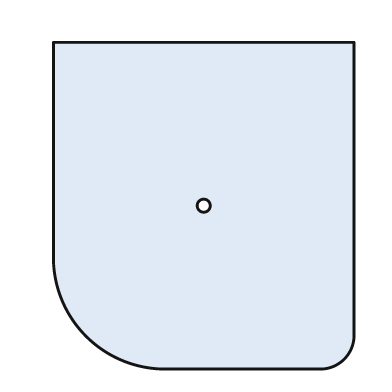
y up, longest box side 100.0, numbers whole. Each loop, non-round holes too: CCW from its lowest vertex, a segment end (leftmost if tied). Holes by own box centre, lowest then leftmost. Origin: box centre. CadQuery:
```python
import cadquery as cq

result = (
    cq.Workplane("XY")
    .moveTo(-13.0, -50.0)
    .lineTo(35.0, -50.0)
    .threePointArc((43.0, -47.0), (46.0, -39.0))
    .lineTo(46.0, 50.0)
    .lineTo(-46.0, 50.0)
    .lineTo(-46.0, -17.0)
    .threePointArc((-36.0, -40.0), (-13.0, -50.0))
    .close()
    .moveTo(0.0, 0.0)
    .circle(2.0)
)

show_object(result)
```